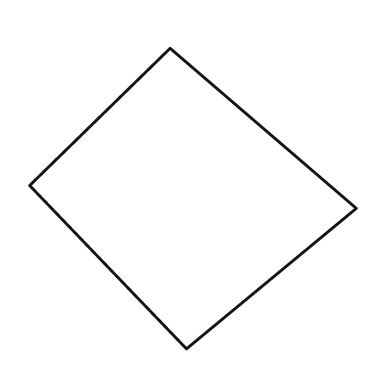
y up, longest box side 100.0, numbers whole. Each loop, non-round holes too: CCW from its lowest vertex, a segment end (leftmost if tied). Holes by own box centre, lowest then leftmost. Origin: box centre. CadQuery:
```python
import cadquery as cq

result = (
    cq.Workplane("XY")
    .moveTo(-2.0, -46.0)
    .lineTo(50.0, -3.0)
    .lineTo(-7.0, 46.0)
    .lineTo(-50.0, 4.0)
    .close()
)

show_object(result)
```